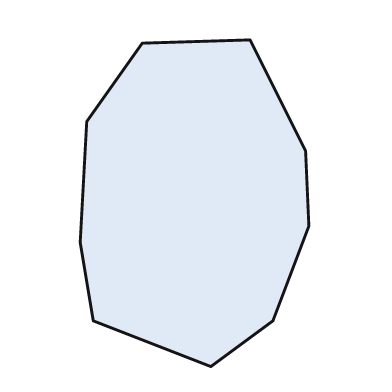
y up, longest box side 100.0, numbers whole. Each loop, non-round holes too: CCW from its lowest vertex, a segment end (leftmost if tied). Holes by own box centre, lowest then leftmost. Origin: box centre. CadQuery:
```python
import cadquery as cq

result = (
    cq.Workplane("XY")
    .moveTo(5.0, -50.0)
    .lineTo(24.0, -36.0)
    .lineTo(35.0, -7.0)
    .lineTo(34.0, 16.0)
    .lineTo(17.0, 50.0)
    .lineTo(-16.0, 49.0)
    .lineTo(-33.0, 25.0)
    .lineTo(-35.0, -12.0)
    .lineTo(-31.0, -36.0)
    .close()
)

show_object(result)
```